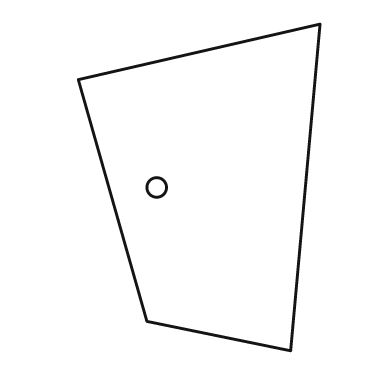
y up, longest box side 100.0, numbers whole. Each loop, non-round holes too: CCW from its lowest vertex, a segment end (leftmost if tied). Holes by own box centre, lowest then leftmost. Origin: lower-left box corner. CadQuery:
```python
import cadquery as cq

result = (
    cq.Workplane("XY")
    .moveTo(65.0, 0.0)
    .lineTo(74.0, 100.0)
    .lineTo(0.0, 83.0)
    .lineTo(21.0, 9.0)
    .close()
    .moveTo(24.0, 50.0)
    .circle(3.0)
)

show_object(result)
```